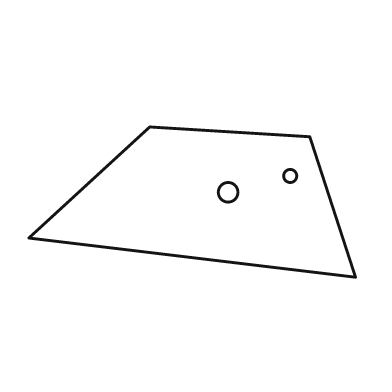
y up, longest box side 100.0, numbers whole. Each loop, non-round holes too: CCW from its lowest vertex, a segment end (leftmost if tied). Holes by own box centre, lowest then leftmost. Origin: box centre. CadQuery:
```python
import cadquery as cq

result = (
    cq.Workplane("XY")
    .moveTo(50.0, -23.0)
    .lineTo(36.0, 20.0)
    .lineTo(-13.0, 23.0)
    .lineTo(-50.0, -11.0)
    .close()
    .moveTo(11.0, 3.0)
    .circle(3.0)
    .moveTo(30.0, 8.0)
    .circle(2.0)
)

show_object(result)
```